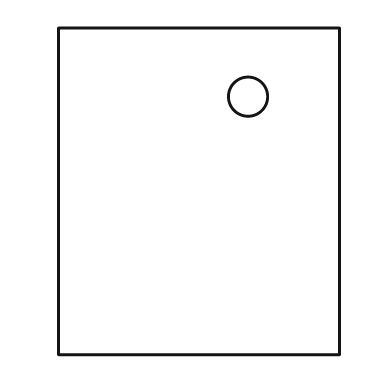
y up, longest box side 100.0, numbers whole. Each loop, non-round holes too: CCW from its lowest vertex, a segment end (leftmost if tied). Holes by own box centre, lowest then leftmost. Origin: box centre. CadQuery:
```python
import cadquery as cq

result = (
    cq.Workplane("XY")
    .moveTo(-43.0, -50.0)
    .lineTo(43.0, -50.0)
    .lineTo(43.0, 50.0)
    .lineTo(-43.0, 50.0)
    .close()
    .moveTo(15.0, 29.0)
    .circle(6.0)
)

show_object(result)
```